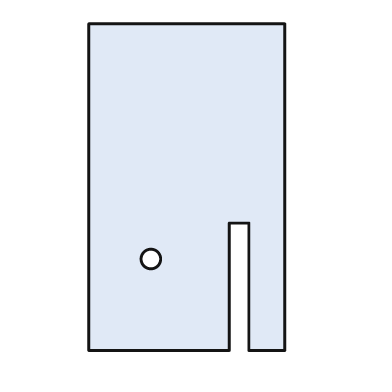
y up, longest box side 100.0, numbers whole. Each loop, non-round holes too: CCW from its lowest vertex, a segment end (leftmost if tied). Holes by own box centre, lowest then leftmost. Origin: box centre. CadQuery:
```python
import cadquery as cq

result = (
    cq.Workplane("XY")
    .moveTo(-30.0, -50.0)
    .lineTo(13.0, -50.0)
    .lineTo(13.0, -11.0)
    .lineTo(19.0, -11.0)
    .lineTo(19.0, -50.0)
    .lineTo(30.0, -50.0)
    .lineTo(30.0, 50.0)
    .lineTo(-30.0, 50.0)
    .close()
    .moveTo(-11.0, -22.0)
    .circle(3.0)
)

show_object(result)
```